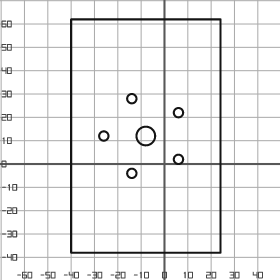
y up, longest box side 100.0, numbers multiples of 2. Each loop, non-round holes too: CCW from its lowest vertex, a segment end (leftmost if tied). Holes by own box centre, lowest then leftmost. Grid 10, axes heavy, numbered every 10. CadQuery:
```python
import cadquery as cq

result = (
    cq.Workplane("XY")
    .moveTo(-40.0, -38.0)
    .lineTo(24.0, -38.0)
    .lineTo(24.0, 62.0)
    .lineTo(-40.0, 62.0)
    .close()
    .moveTo(-14.0, -4.0)
    .circle(2.0)
    .moveTo(6.0, 2.0)
    .circle(2.0)
    .moveTo(-26.0, 12.0)
    .circle(2.0)
    .moveTo(-8.0, 12.0)
    .circle(4.0)
    .moveTo(6.0, 22.0)
    .circle(2.0)
    .moveTo(-14.0, 28.0)
    .circle(2.0)
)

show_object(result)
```